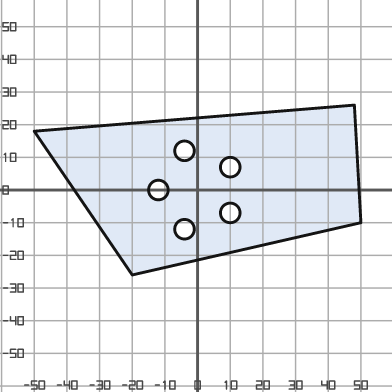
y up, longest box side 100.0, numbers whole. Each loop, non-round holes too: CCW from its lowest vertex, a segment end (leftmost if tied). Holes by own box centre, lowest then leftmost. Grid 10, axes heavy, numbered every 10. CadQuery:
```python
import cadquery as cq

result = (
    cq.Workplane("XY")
    .moveTo(-20.0, -26.0)
    .lineTo(50.0, -10.0)
    .lineTo(48.0, 26.0)
    .lineTo(-50.0, 18.0)
    .close()
    .moveTo(-4.0, -12.0)
    .circle(3.0)
    .moveTo(10.0, -7.0)
    .circle(3.0)
    .moveTo(-12.0, 0.0)
    .circle(3.0)
    .moveTo(10.0, 7.0)
    .circle(3.0)
    .moveTo(-4.0, 12.0)
    .circle(3.0)
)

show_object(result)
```